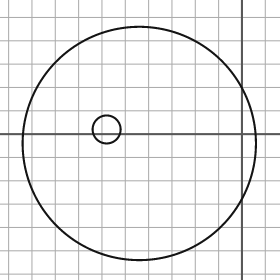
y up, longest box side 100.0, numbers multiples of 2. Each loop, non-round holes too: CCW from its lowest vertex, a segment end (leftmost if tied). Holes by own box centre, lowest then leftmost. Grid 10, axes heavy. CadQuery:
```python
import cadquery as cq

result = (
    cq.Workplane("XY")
    .moveTo(-44.0, -4.0)
    .circle(50.0)
    .moveTo(-58.0, 2.0)
    .circle(6.0)
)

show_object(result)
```